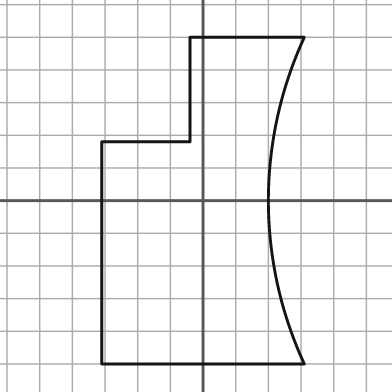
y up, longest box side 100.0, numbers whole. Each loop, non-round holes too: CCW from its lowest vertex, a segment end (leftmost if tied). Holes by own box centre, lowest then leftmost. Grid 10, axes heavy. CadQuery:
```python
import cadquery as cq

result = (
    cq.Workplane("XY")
    .moveTo(-31.0, -50.0)
    .lineTo(31.0, -50.0)
    .threePointArc((20.0, 0.0), (31.0, 50.0))
    .lineTo(-4.0, 50.0)
    .lineTo(-4.0, 18.0)
    .lineTo(-31.0, 18.0)
    .close()
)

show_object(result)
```